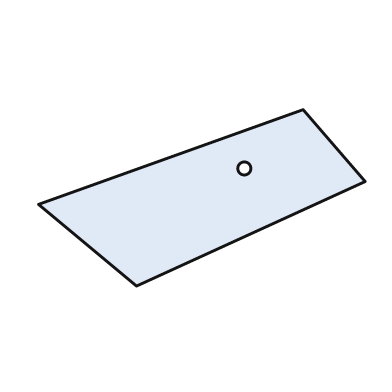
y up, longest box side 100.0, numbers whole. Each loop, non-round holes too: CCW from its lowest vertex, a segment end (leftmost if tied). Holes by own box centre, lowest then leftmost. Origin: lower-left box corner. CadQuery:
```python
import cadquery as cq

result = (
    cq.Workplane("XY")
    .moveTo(30.0, 0.0)
    .lineTo(100.0, 32.0)
    .lineTo(81.0, 54.0)
    .lineTo(0.0, 25.0)
    .close()
    .moveTo(63.0, 36.0)
    .circle(2.0)
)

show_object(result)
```